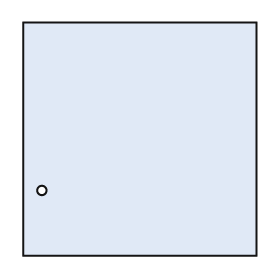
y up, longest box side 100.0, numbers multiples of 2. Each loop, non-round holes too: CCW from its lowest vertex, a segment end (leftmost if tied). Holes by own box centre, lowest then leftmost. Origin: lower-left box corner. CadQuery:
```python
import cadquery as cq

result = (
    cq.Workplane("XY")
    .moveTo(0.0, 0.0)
    .lineTo(100.0, 0.0)
    .lineTo(100.0, 100.0)
    .lineTo(0.0, 100.0)
    .close()
    .moveTo(8.0, 28.0)
    .circle(2.0)
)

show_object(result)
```